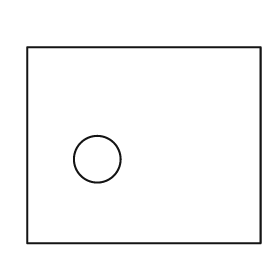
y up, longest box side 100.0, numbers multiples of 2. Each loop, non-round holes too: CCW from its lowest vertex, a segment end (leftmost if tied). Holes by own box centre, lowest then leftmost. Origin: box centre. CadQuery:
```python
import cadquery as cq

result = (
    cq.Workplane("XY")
    .moveTo(-50.0, -42.0)
    .lineTo(50.0, -42.0)
    .lineTo(50.0, 42.0)
    .lineTo(-50.0, 42.0)
    .close()
    .moveTo(-20.0, -6.0)
    .circle(10.0)
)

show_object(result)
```